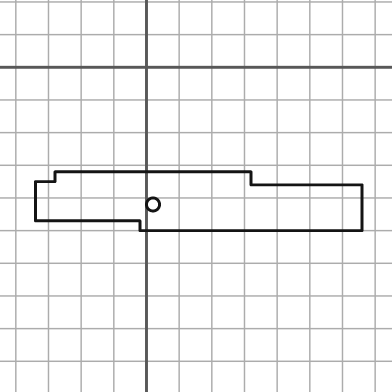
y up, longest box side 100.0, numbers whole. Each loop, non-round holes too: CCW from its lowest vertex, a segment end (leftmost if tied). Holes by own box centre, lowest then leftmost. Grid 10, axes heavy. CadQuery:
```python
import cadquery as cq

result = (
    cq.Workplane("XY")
    .moveTo(-2.0, -50.0)
    .lineTo(66.0, -50.0)
    .lineTo(66.0, -36.0)
    .lineTo(32.0, -36.0)
    .lineTo(32.0, -32.0)
    .lineTo(-28.0, -32.0)
    .lineTo(-28.0, -35.0)
    .lineTo(-34.0, -35.0)
    .lineTo(-34.0, -47.0)
    .lineTo(-2.0, -47.0)
    .close()
    .moveTo(2.0, -42.0)
    .circle(2.0)
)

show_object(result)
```